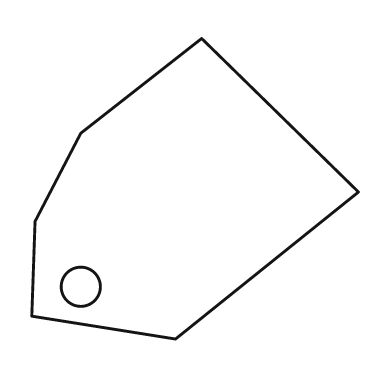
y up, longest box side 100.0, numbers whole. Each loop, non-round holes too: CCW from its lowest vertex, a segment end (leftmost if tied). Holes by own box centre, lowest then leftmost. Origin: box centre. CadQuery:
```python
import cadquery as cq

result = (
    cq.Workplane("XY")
    .moveTo(-6.0, -46.0)
    .lineTo(50.0, -1.0)
    .lineTo(2.0, 46.0)
    .lineTo(-35.0, 17.0)
    .lineTo(-49.0, -10.0)
    .lineTo(-50.0, -39.0)
    .close()
    .moveTo(-35.0, -30.0)
    .circle(6.0)
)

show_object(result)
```